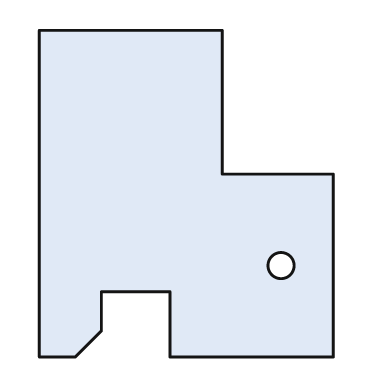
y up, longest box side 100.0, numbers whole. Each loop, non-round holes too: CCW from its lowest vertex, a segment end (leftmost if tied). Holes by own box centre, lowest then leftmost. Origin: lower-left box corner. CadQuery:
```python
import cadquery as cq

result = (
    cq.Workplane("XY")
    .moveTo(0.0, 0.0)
    .lineTo(11.0, 0.0)
    .lineTo(19.0, 8.0)
    .lineTo(19.0, 20.0)
    .lineTo(40.0, 20.0)
    .lineTo(40.0, 0.0)
    .lineTo(90.0, 0.0)
    .lineTo(90.0, 56.0)
    .lineTo(56.0, 56.0)
    .lineTo(56.0, 100.0)
    .lineTo(0.0, 100.0)
    .close()
    .moveTo(74.0, 28.0)
    .circle(4.0)
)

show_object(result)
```